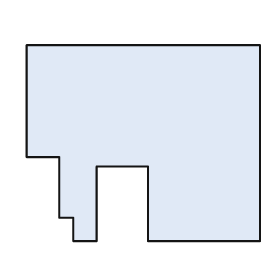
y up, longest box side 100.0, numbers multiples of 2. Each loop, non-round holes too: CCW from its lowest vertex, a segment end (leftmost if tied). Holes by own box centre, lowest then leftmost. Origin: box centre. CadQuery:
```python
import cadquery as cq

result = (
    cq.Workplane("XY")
    .moveTo(-30.0, -42.0)
    .lineTo(-20.0, -42.0)
    .lineTo(-20.0, -10.0)
    .lineTo(2.0, -10.0)
    .lineTo(2.0, -42.0)
    .lineTo(50.0, -42.0)
    .lineTo(50.0, 42.0)
    .lineTo(-50.0, 42.0)
    .lineTo(-50.0, -6.0)
    .lineTo(-36.0, -6.0)
    .lineTo(-36.0, -32.0)
    .lineTo(-30.0, -32.0)
    .close()
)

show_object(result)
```